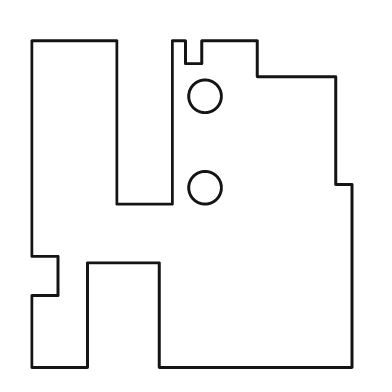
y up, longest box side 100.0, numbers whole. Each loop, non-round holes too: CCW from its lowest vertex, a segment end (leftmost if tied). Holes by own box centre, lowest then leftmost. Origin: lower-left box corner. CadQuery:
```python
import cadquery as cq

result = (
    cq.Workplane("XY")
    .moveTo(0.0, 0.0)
    .lineTo(17.0, 0.0)
    .lineTo(17.0, 32.0)
    .lineTo(39.0, 32.0)
    .lineTo(39.0, 0.0)
    .lineTo(98.0, 0.0)
    .lineTo(98.0, 56.0)
    .lineTo(93.0, 56.0)
    .lineTo(93.0, 89.0)
    .lineTo(69.0, 89.0)
    .lineTo(69.0, 100.0)
    .lineTo(52.0, 100.0)
    .lineTo(52.0, 93.0)
    .lineTo(47.0, 93.0)
    .lineTo(47.0, 100.0)
    .lineTo(43.0, 100.0)
    .lineTo(43.0, 50.0)
    .lineTo(26.0, 50.0)
    .lineTo(26.0, 100.0)
    .lineTo(0.0, 100.0)
    .lineTo(0.0, 34.0)
    .lineTo(8.0, 34.0)
    .lineTo(8.0, 22.0)
    .lineTo(0.0, 22.0)
    .close()
    .moveTo(53.0, 55.0)
    .circle(5.0)
    .moveTo(53.0, 83.0)
    .circle(5.0)
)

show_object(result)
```